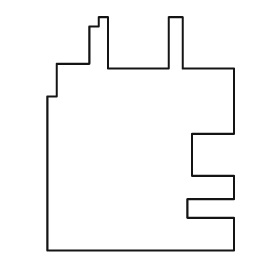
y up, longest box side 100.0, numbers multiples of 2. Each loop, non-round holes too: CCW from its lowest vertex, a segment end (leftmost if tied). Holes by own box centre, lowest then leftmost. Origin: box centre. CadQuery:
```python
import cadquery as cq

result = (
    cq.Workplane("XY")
    .moveTo(-40.0, -50.0)
    .lineTo(40.0, -50.0)
    .lineTo(40.0, -36.0)
    .lineTo(20.0, -36.0)
    .lineTo(20.0, -28.0)
    .lineTo(40.0, -28.0)
    .lineTo(40.0, -18.0)
    .lineTo(22.0, -18.0)
    .lineTo(22.0, 0.0)
    .lineTo(40.0, 0.0)
    .lineTo(40.0, 28.0)
    .lineTo(18.0, 28.0)
    .lineTo(18.0, 50.0)
    .lineTo(12.0, 50.0)
    .lineTo(12.0, 28.0)
    .lineTo(-14.0, 28.0)
    .lineTo(-14.0, 50.0)
    .lineTo(-18.0, 50.0)
    .lineTo(-18.0, 46.0)
    .lineTo(-22.0, 46.0)
    .lineTo(-22.0, 30.0)
    .lineTo(-36.0, 30.0)
    .lineTo(-36.0, 16.0)
    .lineTo(-40.0, 16.0)
    .close()
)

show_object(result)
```